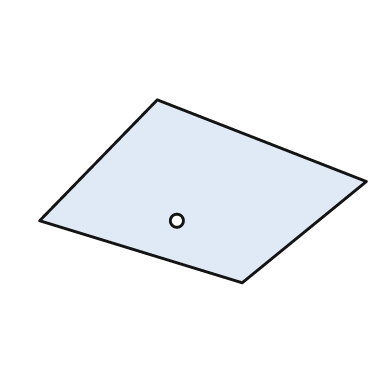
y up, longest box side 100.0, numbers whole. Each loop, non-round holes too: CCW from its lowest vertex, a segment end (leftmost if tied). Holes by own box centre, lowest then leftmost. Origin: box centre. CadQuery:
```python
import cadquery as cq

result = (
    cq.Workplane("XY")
    .moveTo(12.0, -28.0)
    .lineTo(50.0, 3.0)
    .lineTo(-14.0, 28.0)
    .lineTo(-50.0, -9.0)
    .close()
    .moveTo(-8.0, -9.0)
    .circle(2.0)
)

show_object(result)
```